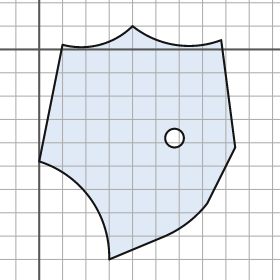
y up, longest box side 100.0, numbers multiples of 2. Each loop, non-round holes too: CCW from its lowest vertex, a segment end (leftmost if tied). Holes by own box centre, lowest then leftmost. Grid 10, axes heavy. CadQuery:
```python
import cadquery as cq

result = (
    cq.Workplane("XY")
    .moveTo(30.0, -90.0)
    .lineTo(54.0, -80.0)
    .threePointArc((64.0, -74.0), (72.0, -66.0))
    .lineTo(84.0, -42.0)
    .lineTo(78.0, 4.0)
    .threePointArc((58.0, 2.0), (40.0, 10.0))
    .threePointArc((26.0, 2.0), (10.0, 2.0))
    .lineTo(0.0, -48.0)
    .threePointArc((22.0, -64.0), (30.0, -90.0))
    .close()
    .moveTo(58.0, -38.0)
    .circle(4.0)
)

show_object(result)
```